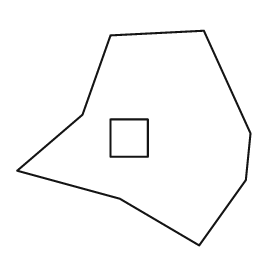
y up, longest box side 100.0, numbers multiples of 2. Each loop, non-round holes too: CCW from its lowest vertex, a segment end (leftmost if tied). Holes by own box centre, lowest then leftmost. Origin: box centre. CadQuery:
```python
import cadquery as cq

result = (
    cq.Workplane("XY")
    .moveTo(28.0, -46.0)
    .lineTo(48.0, -18.0)
    .lineTo(50.0, 2.0)
    .lineTo(30.0, 46.0)
    .lineTo(-10.0, 44.0)
    .lineTo(-22.0, 10.0)
    .lineTo(-50.0, -14.0)
    .lineTo(-6.0, -26.0)
    .close()
    .moveTo(-10.0, -8.0)
    .lineTo(6.0, -8.0)
    .lineTo(6.0, 8.0)
    .lineTo(-10.0, 8.0)
    .close()
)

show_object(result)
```